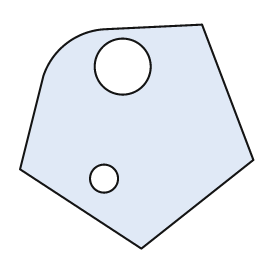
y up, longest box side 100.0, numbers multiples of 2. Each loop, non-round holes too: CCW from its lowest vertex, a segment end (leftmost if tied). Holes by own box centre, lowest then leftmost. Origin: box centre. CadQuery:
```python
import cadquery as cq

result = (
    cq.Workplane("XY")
    .moveTo(2.0, -48.0)
    .lineTo(50.0, -10.0)
    .lineTo(28.0, 48.0)
    .lineTo(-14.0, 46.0)
    .threePointArc((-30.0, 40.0), (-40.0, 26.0))
    .lineTo(-50.0, -14.0)
    .close()
    .moveTo(-14.0, -18.0)
    .circle(6.0)
    .moveTo(-6.0, 30.0)
    .circle(12.0)
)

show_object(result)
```